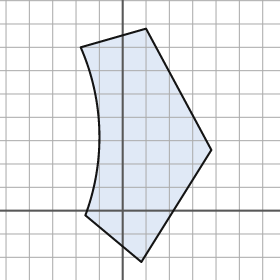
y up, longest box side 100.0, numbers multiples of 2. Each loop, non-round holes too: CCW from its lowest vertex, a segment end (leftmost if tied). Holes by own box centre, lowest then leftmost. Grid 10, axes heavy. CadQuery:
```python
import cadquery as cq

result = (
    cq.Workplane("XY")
    .moveTo(8.0, -22.0)
    .lineTo(38.0, 26.0)
    .lineTo(10.0, 78.0)
    .lineTo(-18.0, 70.0)
    .threePointArc((-10.0, 34.0), (-16.0, -2.0))
    .close()
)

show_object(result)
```